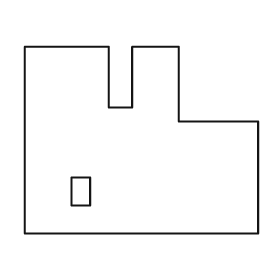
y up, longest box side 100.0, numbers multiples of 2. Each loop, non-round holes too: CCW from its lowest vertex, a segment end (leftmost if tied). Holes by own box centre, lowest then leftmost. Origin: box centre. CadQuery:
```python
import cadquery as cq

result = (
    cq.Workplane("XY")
    .moveTo(-50.0, -40.0)
    .lineTo(50.0, -40.0)
    .lineTo(50.0, 8.0)
    .lineTo(16.0, 8.0)
    .lineTo(16.0, 40.0)
    .lineTo(-4.0, 40.0)
    .lineTo(-4.0, 14.0)
    .lineTo(-14.0, 14.0)
    .lineTo(-14.0, 40.0)
    .lineTo(-50.0, 40.0)
    .close()
    .moveTo(-30.0, -28.0)
    .lineTo(-22.0, -28.0)
    .lineTo(-22.0, -16.0)
    .lineTo(-30.0, -16.0)
    .close()
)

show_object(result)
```